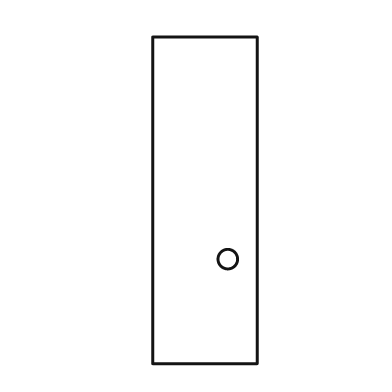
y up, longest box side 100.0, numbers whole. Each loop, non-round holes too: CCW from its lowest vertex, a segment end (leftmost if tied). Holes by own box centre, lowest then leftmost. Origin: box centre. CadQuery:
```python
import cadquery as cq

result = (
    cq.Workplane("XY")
    .moveTo(-16.0, -50.0)
    .lineTo(16.0, -50.0)
    .lineTo(16.0, 50.0)
    .lineTo(-16.0, 50.0)
    .close()
    .moveTo(7.0, -18.0)
    .circle(3.0)
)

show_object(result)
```